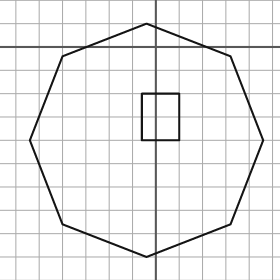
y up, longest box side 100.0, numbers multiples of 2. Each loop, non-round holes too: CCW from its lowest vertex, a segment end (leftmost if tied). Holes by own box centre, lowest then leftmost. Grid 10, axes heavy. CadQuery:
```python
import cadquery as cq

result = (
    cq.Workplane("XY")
    .moveTo(-4.0, -90.0)
    .lineTo(32.0, -76.0)
    .lineTo(46.0, -40.0)
    .lineTo(32.0, -4.0)
    .lineTo(-4.0, 10.0)
    .lineTo(-40.0, -4.0)
    .lineTo(-54.0, -40.0)
    .lineTo(-40.0, -76.0)
    .close()
    .moveTo(-6.0, -40.0)
    .lineTo(10.0, -40.0)
    .lineTo(10.0, -20.0)
    .lineTo(-6.0, -20.0)
    .close()
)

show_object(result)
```